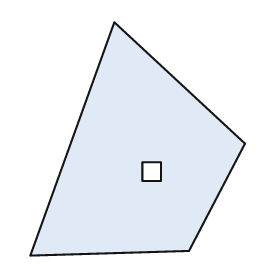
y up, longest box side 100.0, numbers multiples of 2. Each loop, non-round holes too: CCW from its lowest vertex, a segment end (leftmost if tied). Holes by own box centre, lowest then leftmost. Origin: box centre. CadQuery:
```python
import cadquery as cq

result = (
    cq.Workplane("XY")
    .moveTo(-46.0, -50.0)
    .lineTo(22.0, -48.0)
    .lineTo(46.0, -2.0)
    .lineTo(-10.0, 50.0)
    .close()
    .moveTo(2.0, -18.0)
    .lineTo(10.0, -18.0)
    .lineTo(10.0, -10.0)
    .lineTo(2.0, -10.0)
    .close()
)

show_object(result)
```